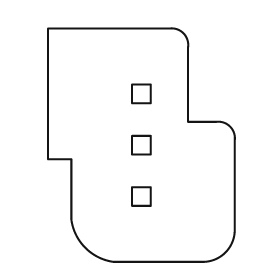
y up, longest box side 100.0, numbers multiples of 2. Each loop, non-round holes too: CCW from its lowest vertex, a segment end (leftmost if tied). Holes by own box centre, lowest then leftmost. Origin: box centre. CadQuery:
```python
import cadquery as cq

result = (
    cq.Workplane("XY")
    .moveTo(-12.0, -50.0)
    .lineTo(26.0, -50.0)
    .threePointArc((36.0, -46.0), (40.0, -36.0))
    .lineTo(40.0, 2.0)
    .threePointArc((38.0, 8.0), (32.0, 10.0))
    .lineTo(20.0, 10.0)
    .lineTo(20.0, 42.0)
    .threePointArc((18.0, 48.0), (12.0, 50.0))
    .lineTo(-40.0, 50.0)
    .lineTo(-40.0, -6.0)
    .lineTo(-30.0, -6.0)
    .lineTo(-30.0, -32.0)
    .threePointArc((-24.0, -44.0), (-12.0, -50.0))
    .close()
    .moveTo(-4.0, -26.0)
    .lineTo(4.0, -26.0)
    .lineTo(4.0, -18.0)
    .lineTo(-4.0, -18.0)
    .close()
    .moveTo(-4.0, -4.0)
    .lineTo(4.0, -4.0)
    .lineTo(4.0, 4.0)
    .lineTo(-4.0, 4.0)
    .close()
    .moveTo(-4.0, 18.0)
    .lineTo(4.0, 18.0)
    .lineTo(4.0, 26.0)
    .lineTo(-4.0, 26.0)
    .close()
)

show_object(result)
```